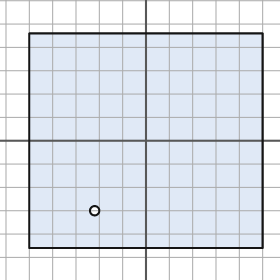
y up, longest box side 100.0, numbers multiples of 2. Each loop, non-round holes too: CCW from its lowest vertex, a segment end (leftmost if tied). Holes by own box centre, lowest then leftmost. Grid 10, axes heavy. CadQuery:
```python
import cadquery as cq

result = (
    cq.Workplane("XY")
    .moveTo(-50.0, -46.0)
    .lineTo(50.0, -46.0)
    .lineTo(50.0, 46.0)
    .lineTo(-50.0, 46.0)
    .close()
    .moveTo(-22.0, -30.0)
    .circle(2.0)
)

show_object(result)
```